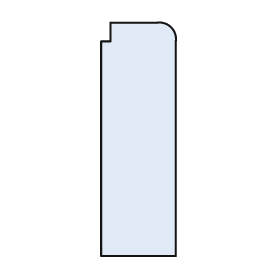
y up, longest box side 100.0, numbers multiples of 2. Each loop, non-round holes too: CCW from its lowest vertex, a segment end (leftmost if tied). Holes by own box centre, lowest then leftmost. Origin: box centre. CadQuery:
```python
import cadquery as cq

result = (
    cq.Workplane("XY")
    .moveTo(-16.0, -50.0)
    .lineTo(16.0, -50.0)
    .lineTo(16.0, 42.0)
    .threePointArc((14.0, 48.0), (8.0, 50.0))
    .lineTo(-12.0, 50.0)
    .lineTo(-12.0, 42.0)
    .lineTo(-16.0, 42.0)
    .close()
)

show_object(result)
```